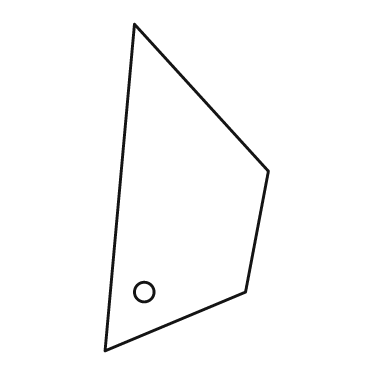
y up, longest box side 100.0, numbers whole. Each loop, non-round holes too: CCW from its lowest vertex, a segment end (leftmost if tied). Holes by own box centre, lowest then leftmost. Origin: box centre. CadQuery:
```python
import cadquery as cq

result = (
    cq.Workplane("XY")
    .moveTo(-25.0, -50.0)
    .lineTo(18.0, -32.0)
    .lineTo(25.0, 5.0)
    .lineTo(-16.0, 50.0)
    .close()
    .moveTo(-13.0, -32.0)
    .circle(3.0)
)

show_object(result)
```